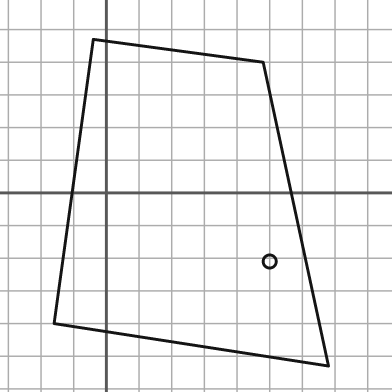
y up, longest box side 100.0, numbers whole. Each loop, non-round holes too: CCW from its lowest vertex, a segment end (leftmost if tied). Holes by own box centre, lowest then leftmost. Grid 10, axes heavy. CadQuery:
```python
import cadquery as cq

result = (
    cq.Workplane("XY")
    .moveTo(68.0, -53.0)
    .lineTo(48.0, 40.0)
    .lineTo(-4.0, 47.0)
    .lineTo(-16.0, -40.0)
    .close()
    .moveTo(50.0, -21.0)
    .circle(2.0)
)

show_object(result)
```